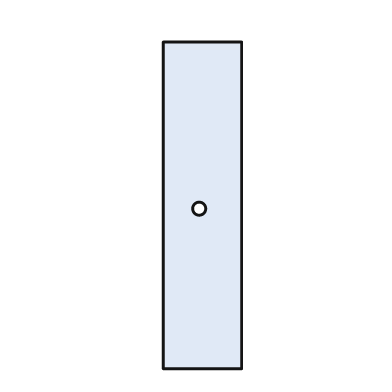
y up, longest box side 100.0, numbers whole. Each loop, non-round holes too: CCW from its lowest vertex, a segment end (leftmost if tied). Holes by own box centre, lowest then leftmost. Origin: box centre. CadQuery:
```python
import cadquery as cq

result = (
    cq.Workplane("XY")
    .moveTo(-12.0, -50.0)
    .lineTo(12.0, -50.0)
    .lineTo(12.0, 50.0)
    .lineTo(-12.0, 50.0)
    .close()
    .moveTo(-1.0, -1.0)
    .circle(2.0)
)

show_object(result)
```